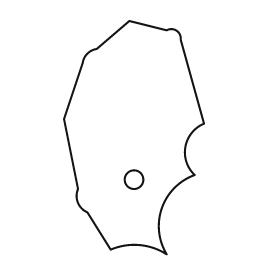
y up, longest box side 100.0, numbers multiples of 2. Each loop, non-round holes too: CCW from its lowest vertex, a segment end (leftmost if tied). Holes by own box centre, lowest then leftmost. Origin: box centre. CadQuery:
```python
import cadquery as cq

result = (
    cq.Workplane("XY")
    .moveTo(14.0, -50.0)
    .threePointArc((12.0, -30.0), (26.0, -16.0))
    .threePointArc((22.0, -4.0), (30.0, 6.0))
    .lineTo(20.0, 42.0)
    .threePointArc((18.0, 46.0), (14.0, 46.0))
    .lineTo(-2.0, 50.0)
    .lineTo(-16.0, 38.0)
    .threePointArc((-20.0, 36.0), (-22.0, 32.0))
    .lineTo(-30.0, 8.0)
    .lineTo(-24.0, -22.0)
    .threePointArc((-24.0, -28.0), (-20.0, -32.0))
    .lineTo(-10.0, -48.0)
    .threePointArc((2.0, -46.0), (14.0, -50.0))
    .close()
    .moveTo(0.0, -18.0)
    .circle(4.0)
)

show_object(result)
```